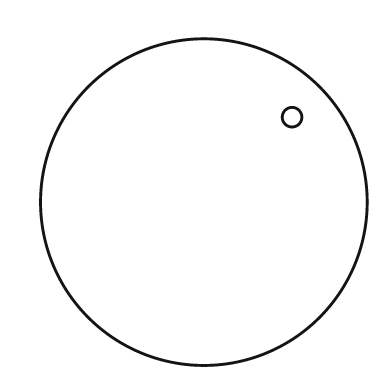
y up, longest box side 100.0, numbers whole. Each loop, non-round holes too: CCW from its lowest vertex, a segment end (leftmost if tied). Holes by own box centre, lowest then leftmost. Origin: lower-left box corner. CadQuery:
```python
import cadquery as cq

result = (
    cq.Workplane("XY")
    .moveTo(50.0, 50.0)
    .circle(50.0)
    .moveTo(77.0, 76.0)
    .circle(3.0)
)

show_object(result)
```